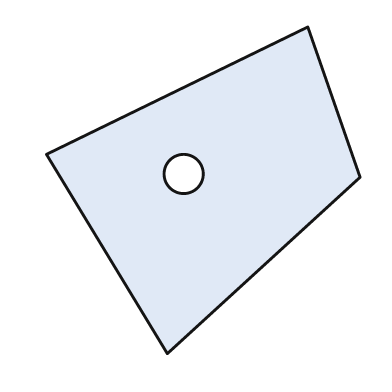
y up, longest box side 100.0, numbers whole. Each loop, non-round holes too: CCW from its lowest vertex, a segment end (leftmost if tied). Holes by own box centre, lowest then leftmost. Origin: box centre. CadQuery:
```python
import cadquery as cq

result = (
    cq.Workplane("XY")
    .moveTo(-11.0, -50.0)
    .lineTo(48.0, 4.0)
    .lineTo(32.0, 50.0)
    .lineTo(-48.0, 11.0)
    .close()
    .moveTo(-6.0, 5.0)
    .circle(6.0)
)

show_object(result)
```